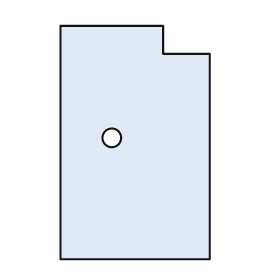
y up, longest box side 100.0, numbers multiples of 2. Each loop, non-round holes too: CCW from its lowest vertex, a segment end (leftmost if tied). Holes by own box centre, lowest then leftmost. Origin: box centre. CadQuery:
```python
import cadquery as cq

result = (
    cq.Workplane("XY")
    .moveTo(-32.0, -50.0)
    .lineTo(32.0, -50.0)
    .lineTo(32.0, 38.0)
    .lineTo(12.0, 38.0)
    .lineTo(12.0, 50.0)
    .lineTo(-32.0, 50.0)
    .close()
    .moveTo(-10.0, 2.0)
    .circle(4.0)
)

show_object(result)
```